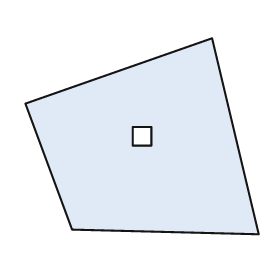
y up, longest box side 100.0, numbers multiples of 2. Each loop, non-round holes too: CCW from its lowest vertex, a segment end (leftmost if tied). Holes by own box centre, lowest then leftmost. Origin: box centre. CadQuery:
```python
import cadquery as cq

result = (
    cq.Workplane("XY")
    .moveTo(50.0, -42.0)
    .lineTo(30.0, 42.0)
    .lineTo(-50.0, 14.0)
    .lineTo(-30.0, -40.0)
    .close()
    .moveTo(-4.0, -4.0)
    .lineTo(4.0, -4.0)
    .lineTo(4.0, 4.0)
    .lineTo(-4.0, 4.0)
    .close()
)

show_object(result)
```